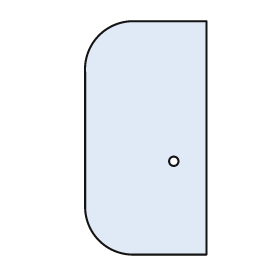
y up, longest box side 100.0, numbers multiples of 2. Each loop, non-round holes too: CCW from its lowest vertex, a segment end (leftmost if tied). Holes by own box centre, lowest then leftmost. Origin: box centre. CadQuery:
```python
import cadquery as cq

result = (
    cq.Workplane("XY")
    .moveTo(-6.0, -50.0)
    .lineTo(26.0, -50.0)
    .lineTo(26.0, 50.0)
    .lineTo(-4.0, 50.0)
    .threePointArc((-20.0, 44.0), (-26.0, 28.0))
    .lineTo(-26.0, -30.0)
    .threePointArc((-20.0, -44.0), (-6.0, -50.0))
    .close()
    .moveTo(12.0, -10.0)
    .circle(2.0)
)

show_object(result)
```